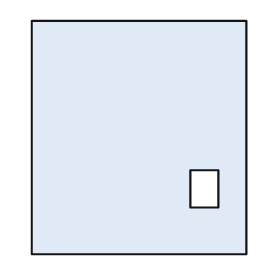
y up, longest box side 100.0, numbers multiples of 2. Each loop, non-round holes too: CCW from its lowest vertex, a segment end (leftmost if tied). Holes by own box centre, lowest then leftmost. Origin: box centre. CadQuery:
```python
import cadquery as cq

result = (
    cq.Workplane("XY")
    .moveTo(-46.0, -50.0)
    .lineTo(46.0, -50.0)
    .lineTo(46.0, 50.0)
    .lineTo(-46.0, 50.0)
    .close()
    .moveTo(22.0, -30.0)
    .lineTo(34.0, -30.0)
    .lineTo(34.0, -14.0)
    .lineTo(22.0, -14.0)
    .close()
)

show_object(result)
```